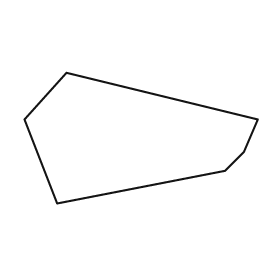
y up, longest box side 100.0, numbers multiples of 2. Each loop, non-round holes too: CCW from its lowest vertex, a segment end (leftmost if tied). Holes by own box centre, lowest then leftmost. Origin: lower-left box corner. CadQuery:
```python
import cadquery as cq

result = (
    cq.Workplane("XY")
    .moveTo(14.0, 0.0)
    .lineTo(86.0, 14.0)
    .lineTo(94.0, 22.0)
    .lineTo(100.0, 36.0)
    .lineTo(18.0, 56.0)
    .lineTo(0.0, 36.0)
    .close()
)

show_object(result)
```